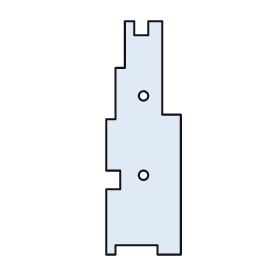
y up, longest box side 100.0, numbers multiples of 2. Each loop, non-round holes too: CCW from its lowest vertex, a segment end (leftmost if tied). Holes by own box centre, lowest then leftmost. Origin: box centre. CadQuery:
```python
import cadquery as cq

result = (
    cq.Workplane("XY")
    .moveTo(-16.0, -50.0)
    .lineTo(-12.0, -50.0)
    .lineTo(-12.0, -46.0)
    .lineTo(6.0, -46.0)
    .lineTo(6.0, -50.0)
    .lineTo(16.0, -50.0)
    .lineTo(16.0, 10.0)
    .lineTo(8.0, 10.0)
    .lineTo(8.0, 50.0)
    .lineTo(2.0, 50.0)
    .lineTo(2.0, 44.0)
    .lineTo(-4.0, 44.0)
    .lineTo(-4.0, 50.0)
    .lineTo(-8.0, 50.0)
    .lineTo(-8.0, 30.0)
    .lineTo(-12.0, 30.0)
    .lineTo(-12.0, 8.0)
    .lineTo(-16.0, 8.0)
    .lineTo(-16.0, -14.0)
    .lineTo(-10.0, -14.0)
    .lineTo(-10.0, -22.0)
    .lineTo(-16.0, -22.0)
    .close()
    .moveTo(0.0, -16.0)
    .circle(2.0)
    .moveTo(0.0, 18.0)
    .circle(2.0)
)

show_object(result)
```